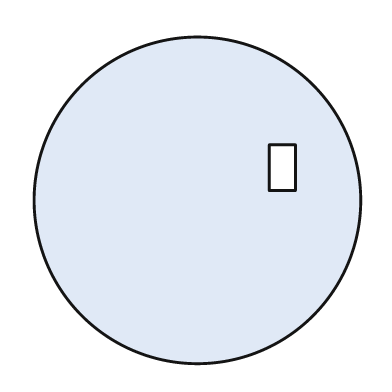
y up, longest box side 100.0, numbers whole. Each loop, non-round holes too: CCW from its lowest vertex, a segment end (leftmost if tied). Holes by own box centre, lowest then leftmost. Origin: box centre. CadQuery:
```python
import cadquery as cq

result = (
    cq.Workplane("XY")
    .moveTo(0.0, 0.0)
    .circle(50.0)
    .moveTo(22.0, 3.0)
    .lineTo(30.0, 3.0)
    .lineTo(30.0, 17.0)
    .lineTo(22.0, 17.0)
    .close()
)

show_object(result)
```